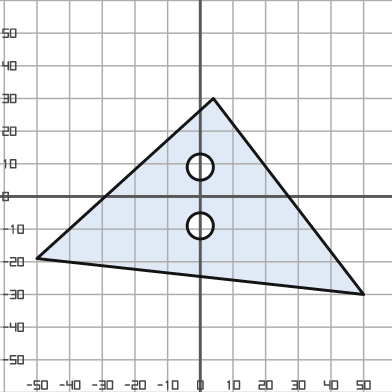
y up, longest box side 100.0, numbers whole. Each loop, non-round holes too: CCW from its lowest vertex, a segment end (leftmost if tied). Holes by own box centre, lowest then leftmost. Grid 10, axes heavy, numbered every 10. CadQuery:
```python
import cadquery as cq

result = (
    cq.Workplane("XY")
    .moveTo(50.0, -30.0)
    .lineTo(4.0, 30.0)
    .lineTo(-50.0, -19.0)
    .close()
    .moveTo(0.0, -9.0)
    .circle(4.0)
    .moveTo(0.0, 9.0)
    .circle(4.0)
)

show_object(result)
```